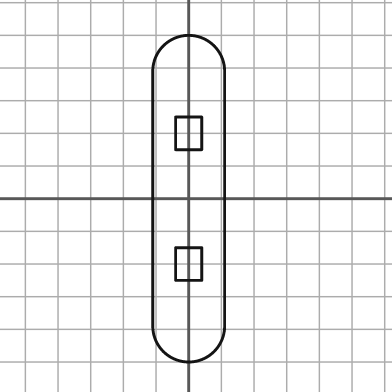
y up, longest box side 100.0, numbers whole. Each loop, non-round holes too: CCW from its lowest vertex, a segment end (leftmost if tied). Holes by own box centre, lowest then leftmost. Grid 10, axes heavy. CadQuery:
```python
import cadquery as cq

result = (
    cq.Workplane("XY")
    .moveTo(-11.0, -39.0)
    .threePointArc((0.0, -50.0), (11.0, -39.0))
    .lineTo(11.0, 39.0)
    .threePointArc((0.0, 50.0), (-11.0, 39.0))
    .close()
    .moveTo(-4.0, -25.0)
    .lineTo(4.0, -25.0)
    .lineTo(4.0, -15.0)
    .lineTo(-4.0, -15.0)
    .close()
    .moveTo(-4.0, 15.0)
    .lineTo(4.0, 15.0)
    .lineTo(4.0, 25.0)
    .lineTo(-4.0, 25.0)
    .close()
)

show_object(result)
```